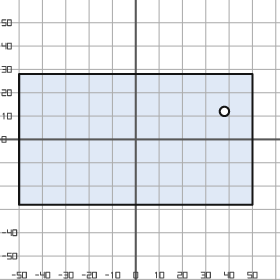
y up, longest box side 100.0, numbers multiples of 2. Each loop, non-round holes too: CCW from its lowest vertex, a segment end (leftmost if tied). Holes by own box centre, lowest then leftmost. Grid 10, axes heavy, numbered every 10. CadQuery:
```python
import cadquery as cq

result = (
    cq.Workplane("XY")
    .moveTo(-50.0, -28.0)
    .lineTo(50.0, -28.0)
    .lineTo(50.0, 28.0)
    .lineTo(-50.0, 28.0)
    .close()
    .moveTo(38.0, 12.0)
    .circle(2.0)
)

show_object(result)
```